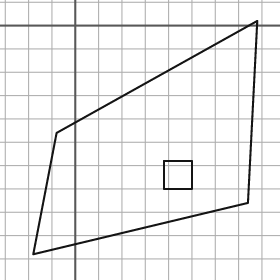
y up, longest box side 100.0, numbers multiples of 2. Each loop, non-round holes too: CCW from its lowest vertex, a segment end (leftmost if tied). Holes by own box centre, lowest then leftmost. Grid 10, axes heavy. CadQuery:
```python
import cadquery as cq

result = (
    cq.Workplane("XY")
    .moveTo(-18.0, -98.0)
    .lineTo(74.0, -76.0)
    .lineTo(78.0, 2.0)
    .lineTo(-8.0, -46.0)
    .close()
    .moveTo(38.0, -70.0)
    .lineTo(50.0, -70.0)
    .lineTo(50.0, -58.0)
    .lineTo(38.0, -58.0)
    .close()
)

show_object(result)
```